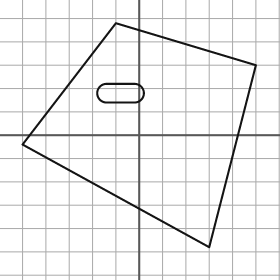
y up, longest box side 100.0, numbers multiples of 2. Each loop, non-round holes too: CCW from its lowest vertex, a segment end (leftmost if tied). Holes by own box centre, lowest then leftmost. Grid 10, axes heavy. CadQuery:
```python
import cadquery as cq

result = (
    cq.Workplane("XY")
    .moveTo(30.0, -48.0)
    .lineTo(50.0, 30.0)
    .lineTo(-10.0, 48.0)
    .lineTo(-50.0, -4.0)
    .close()
    .moveTo(-14.0, 14.0)
    .lineTo(-2.0, 14.0)
    .threePointArc((2.0, 18.0), (-2.0, 22.0))
    .lineTo(-14.0, 22.0)
    .threePointArc((-18.0, 18.0), (-14.0, 14.0))
    .close()
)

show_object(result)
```